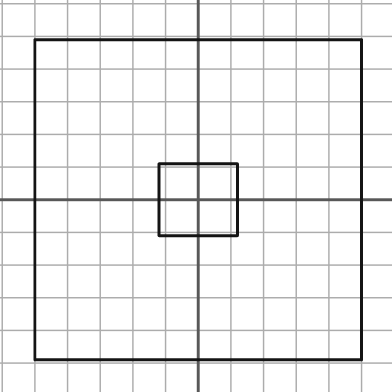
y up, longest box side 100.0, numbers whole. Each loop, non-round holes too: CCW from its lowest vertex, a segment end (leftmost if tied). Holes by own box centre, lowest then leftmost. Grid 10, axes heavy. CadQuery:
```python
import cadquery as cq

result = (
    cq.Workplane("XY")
    .moveTo(-50.0, -49.0)
    .lineTo(50.0, -49.0)
    .lineTo(50.0, 49.0)
    .lineTo(-50.0, 49.0)
    .close()
    .moveTo(-12.0, -11.0)
    .lineTo(12.0, -11.0)
    .lineTo(12.0, 11.0)
    .lineTo(-12.0, 11.0)
    .close()
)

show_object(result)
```